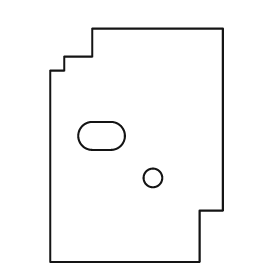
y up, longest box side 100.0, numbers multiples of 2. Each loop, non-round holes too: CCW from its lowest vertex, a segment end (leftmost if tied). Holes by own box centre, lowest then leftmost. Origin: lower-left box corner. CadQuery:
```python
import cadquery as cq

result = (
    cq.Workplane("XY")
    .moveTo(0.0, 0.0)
    .lineTo(64.0, 0.0)
    .lineTo(64.0, 22.0)
    .lineTo(74.0, 22.0)
    .lineTo(74.0, 100.0)
    .lineTo(18.0, 100.0)
    .lineTo(18.0, 88.0)
    .lineTo(6.0, 88.0)
    .lineTo(6.0, 82.0)
    .lineTo(0.0, 82.0)
    .close()
    .moveTo(44.0, 36.0)
    .circle(4.0)
    .moveTo(18.0, 48.0)
    .lineTo(26.0, 48.0)
    .threePointArc((32.0, 54.0), (26.0, 60.0))
    .lineTo(18.0, 60.0)
    .threePointArc((12.0, 54.0), (18.0, 48.0))
    .close()
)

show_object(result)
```